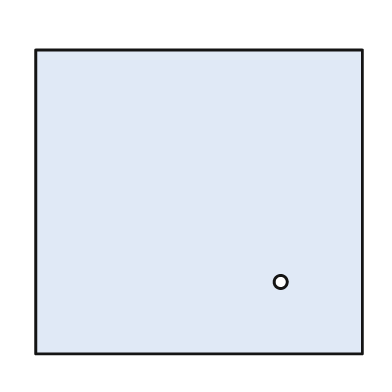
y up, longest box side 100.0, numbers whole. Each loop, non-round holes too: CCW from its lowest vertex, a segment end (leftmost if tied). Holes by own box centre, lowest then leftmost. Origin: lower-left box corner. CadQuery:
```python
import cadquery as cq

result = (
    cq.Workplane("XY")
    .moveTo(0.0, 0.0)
    .lineTo(100.0, 0.0)
    .lineTo(100.0, 93.0)
    .lineTo(0.0, 93.0)
    .close()
    .moveTo(75.0, 22.0)
    .circle(2.0)
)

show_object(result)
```